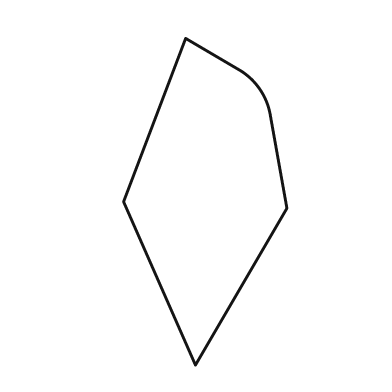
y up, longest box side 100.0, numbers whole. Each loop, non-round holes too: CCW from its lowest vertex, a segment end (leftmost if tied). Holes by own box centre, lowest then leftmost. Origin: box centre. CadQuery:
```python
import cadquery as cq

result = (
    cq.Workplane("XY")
    .moveTo(-3.0, -50.0)
    .lineTo(25.0, -2.0)
    .lineTo(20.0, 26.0)
    .threePointArc((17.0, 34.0), (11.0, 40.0))
    .lineTo(-6.0, 50.0)
    .lineTo(-25.0, 0.0)
    .close()
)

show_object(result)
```